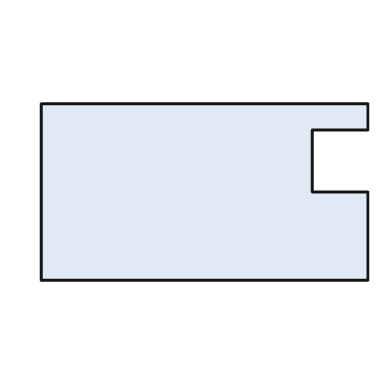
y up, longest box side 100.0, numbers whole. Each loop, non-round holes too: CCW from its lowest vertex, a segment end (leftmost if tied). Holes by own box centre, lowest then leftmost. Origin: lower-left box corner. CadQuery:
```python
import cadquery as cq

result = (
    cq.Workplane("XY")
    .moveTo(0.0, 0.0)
    .lineTo(100.0, 0.0)
    .lineTo(100.0, 27.0)
    .lineTo(83.0, 27.0)
    .lineTo(83.0, 46.0)
    .lineTo(100.0, 46.0)
    .lineTo(100.0, 54.0)
    .lineTo(0.0, 54.0)
    .close()
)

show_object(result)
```